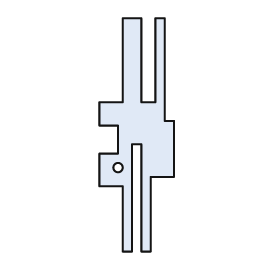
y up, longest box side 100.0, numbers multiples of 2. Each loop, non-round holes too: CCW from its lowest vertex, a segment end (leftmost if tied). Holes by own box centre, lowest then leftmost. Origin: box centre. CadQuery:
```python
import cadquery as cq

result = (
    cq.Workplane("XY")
    .moveTo(-6.0, -50.0)
    .lineTo(-2.0, -50.0)
    .lineTo(-2.0, -4.0)
    .lineTo(2.0, -4.0)
    .lineTo(2.0, -50.0)
    .lineTo(6.0, -50.0)
    .lineTo(6.0, -18.0)
    .lineTo(16.0, -18.0)
    .lineTo(16.0, 6.0)
    .lineTo(12.0, 6.0)
    .lineTo(12.0, 50.0)
    .lineTo(8.0, 50.0)
    .lineTo(8.0, 14.0)
    .lineTo(2.0, 14.0)
    .lineTo(2.0, 50.0)
    .lineTo(-6.0, 50.0)
    .lineTo(-6.0, 14.0)
    .lineTo(-16.0, 14.0)
    .lineTo(-16.0, 4.0)
    .lineTo(-8.0, 4.0)
    .lineTo(-8.0, -8.0)
    .lineTo(-16.0, -8.0)
    .lineTo(-16.0, -22.0)
    .lineTo(-6.0, -22.0)
    .close()
    .moveTo(-8.0, -14.0)
    .circle(2.0)
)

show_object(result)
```